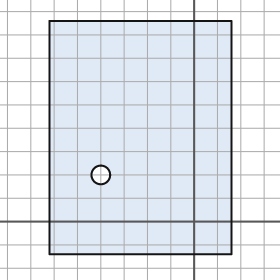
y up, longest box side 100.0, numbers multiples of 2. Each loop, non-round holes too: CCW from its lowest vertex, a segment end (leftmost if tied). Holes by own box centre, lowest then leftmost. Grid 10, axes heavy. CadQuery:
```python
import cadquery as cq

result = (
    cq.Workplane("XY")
    .moveTo(-62.0, -14.0)
    .lineTo(16.0, -14.0)
    .lineTo(16.0, 86.0)
    .lineTo(-62.0, 86.0)
    .close()
    .moveTo(-40.0, 20.0)
    .circle(4.0)
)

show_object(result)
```